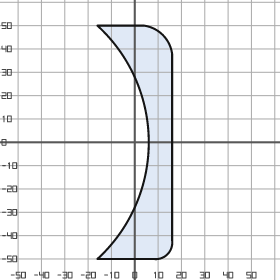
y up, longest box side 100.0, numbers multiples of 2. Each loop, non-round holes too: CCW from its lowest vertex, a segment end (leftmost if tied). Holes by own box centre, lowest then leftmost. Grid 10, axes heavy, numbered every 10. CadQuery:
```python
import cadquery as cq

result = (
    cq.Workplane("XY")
    .moveTo(-16.0, -50.0)
    .lineTo(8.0, -50.0)
    .threePointArc((14.0, -48.0), (16.0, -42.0))
    .lineTo(16.0, 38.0)
    .threePointArc((12.0, 46.0), (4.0, 50.0))
    .lineTo(-16.0, 50.0)
    .threePointArc((6.0, 0.0), (-16.0, -50.0))
    .close()
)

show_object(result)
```